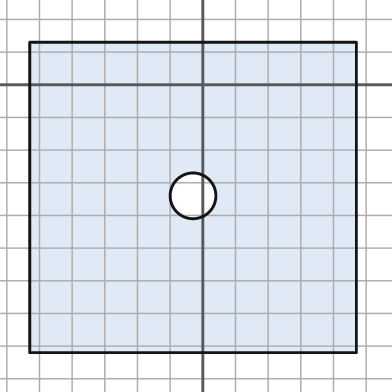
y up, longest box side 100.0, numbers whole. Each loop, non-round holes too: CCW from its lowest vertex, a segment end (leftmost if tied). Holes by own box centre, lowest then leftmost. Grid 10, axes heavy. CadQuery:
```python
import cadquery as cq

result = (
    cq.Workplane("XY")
    .moveTo(-53.0, -82.0)
    .lineTo(47.0, -82.0)
    .lineTo(47.0, 13.0)
    .lineTo(-53.0, 13.0)
    .close()
    .moveTo(-3.0, -34.0)
    .circle(7.0)
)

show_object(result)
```